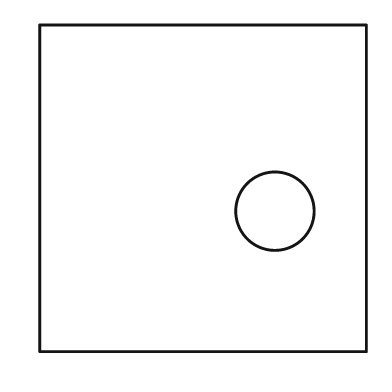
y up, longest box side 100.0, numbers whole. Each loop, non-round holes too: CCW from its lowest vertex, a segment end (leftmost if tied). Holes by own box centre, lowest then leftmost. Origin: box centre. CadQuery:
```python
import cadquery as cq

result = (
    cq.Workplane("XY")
    .moveTo(-50.0, -50.0)
    .lineTo(50.0, -50.0)
    .lineTo(50.0, 50.0)
    .lineTo(-50.0, 50.0)
    .close()
    .moveTo(22.0, -7.0)
    .circle(12.0)
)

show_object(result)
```